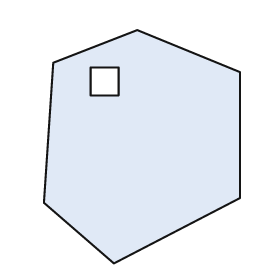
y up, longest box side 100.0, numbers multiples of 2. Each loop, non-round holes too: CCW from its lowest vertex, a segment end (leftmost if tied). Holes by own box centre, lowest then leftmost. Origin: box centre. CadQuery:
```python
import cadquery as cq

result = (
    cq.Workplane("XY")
    .moveTo(-12.0, -50.0)
    .lineTo(42.0, -22.0)
    .lineTo(42.0, 32.0)
    .lineTo(-2.0, 50.0)
    .lineTo(-38.0, 36.0)
    .lineTo(-42.0, -24.0)
    .close()
    .moveTo(-22.0, 22.0)
    .lineTo(-10.0, 22.0)
    .lineTo(-10.0, 34.0)
    .lineTo(-22.0, 34.0)
    .close()
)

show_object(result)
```